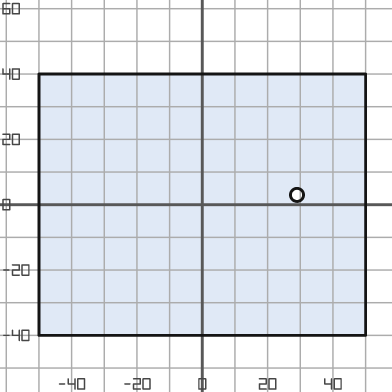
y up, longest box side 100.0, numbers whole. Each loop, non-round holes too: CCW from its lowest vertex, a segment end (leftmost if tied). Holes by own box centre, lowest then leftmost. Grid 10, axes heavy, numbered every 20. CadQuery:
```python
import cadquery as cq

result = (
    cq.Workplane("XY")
    .moveTo(-50.0, -40.0)
    .lineTo(50.0, -40.0)
    .lineTo(50.0, 40.0)
    .lineTo(-50.0, 40.0)
    .close()
    .moveTo(29.0, 3.0)
    .circle(2.0)
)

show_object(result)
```